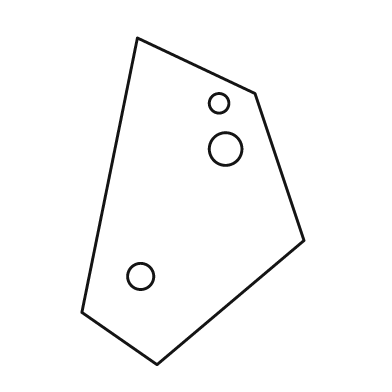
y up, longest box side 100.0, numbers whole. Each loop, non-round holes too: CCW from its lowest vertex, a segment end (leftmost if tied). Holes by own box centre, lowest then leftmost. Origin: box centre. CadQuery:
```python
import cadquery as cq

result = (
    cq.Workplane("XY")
    .moveTo(-11.0, -50.0)
    .lineTo(34.0, -12.0)
    .lineTo(19.0, 33.0)
    .lineTo(-17.0, 50.0)
    .lineTo(-34.0, -34.0)
    .close()
    .moveTo(-16.0, -23.0)
    .circle(4.0)
    .moveTo(10.0, 16.0)
    .circle(5.0)
    .moveTo(8.0, 30.0)
    .circle(3.0)
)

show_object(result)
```